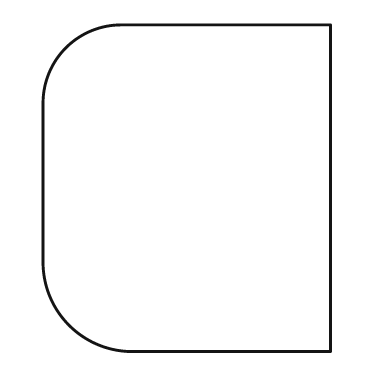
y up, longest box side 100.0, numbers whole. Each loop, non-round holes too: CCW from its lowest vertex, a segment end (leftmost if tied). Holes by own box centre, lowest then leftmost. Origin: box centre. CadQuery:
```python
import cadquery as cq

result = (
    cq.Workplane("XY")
    .moveTo(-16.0, -50.0)
    .lineTo(44.0, -50.0)
    .lineTo(44.0, 50.0)
    .lineTo(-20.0, 50.0)
    .threePointArc((-37.0, 43.0), (-44.0, 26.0))
    .lineTo(-44.0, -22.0)
    .threePointArc((-36.0, -42.0), (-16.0, -50.0))
    .close()
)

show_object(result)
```